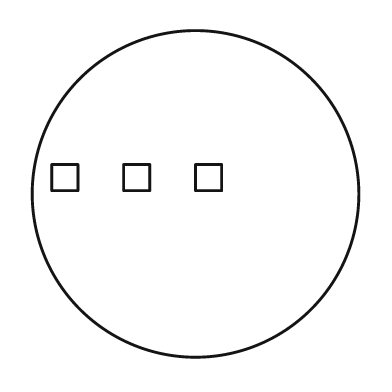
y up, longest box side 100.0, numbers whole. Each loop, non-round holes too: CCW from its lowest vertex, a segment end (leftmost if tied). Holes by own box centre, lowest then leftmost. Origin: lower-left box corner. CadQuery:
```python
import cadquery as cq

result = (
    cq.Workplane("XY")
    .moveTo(50.0, 50.0)
    .circle(50.0)
    .moveTo(6.0, 51.0)
    .lineTo(14.0, 51.0)
    .lineTo(14.0, 59.0)
    .lineTo(6.0, 59.0)
    .close()
    .moveTo(28.0, 51.0)
    .lineTo(36.0, 51.0)
    .lineTo(36.0, 59.0)
    .lineTo(28.0, 59.0)
    .close()
    .moveTo(50.0, 51.0)
    .lineTo(58.0, 51.0)
    .lineTo(58.0, 59.0)
    .lineTo(50.0, 59.0)
    .close()
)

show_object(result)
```